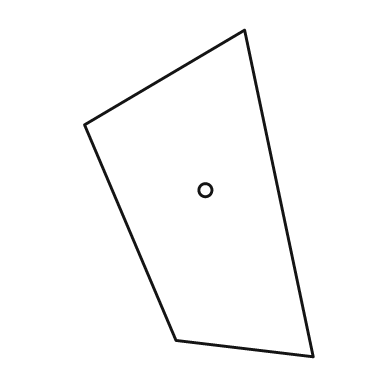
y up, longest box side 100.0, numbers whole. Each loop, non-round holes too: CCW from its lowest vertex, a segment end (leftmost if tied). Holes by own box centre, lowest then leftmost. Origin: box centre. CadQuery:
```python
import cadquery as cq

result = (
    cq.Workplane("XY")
    .moveTo(35.0, -50.0)
    .lineTo(14.0, 50.0)
    .lineTo(-35.0, 21.0)
    .lineTo(-7.0, -45.0)
    .close()
    .moveTo(2.0, 1.0)
    .circle(2.0)
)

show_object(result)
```